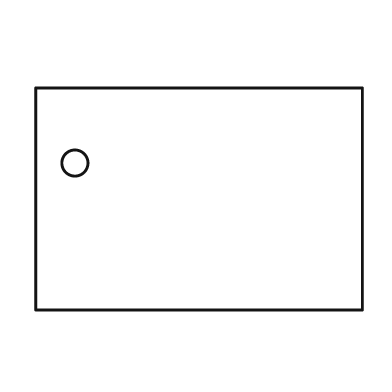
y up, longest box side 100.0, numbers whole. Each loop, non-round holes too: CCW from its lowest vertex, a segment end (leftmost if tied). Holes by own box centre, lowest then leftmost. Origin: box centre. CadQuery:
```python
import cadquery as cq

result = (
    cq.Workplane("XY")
    .moveTo(-50.0, -34.0)
    .lineTo(50.0, -34.0)
    .lineTo(50.0, 34.0)
    .lineTo(-50.0, 34.0)
    .close()
    .moveTo(-38.0, 11.0)
    .circle(4.0)
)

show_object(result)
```